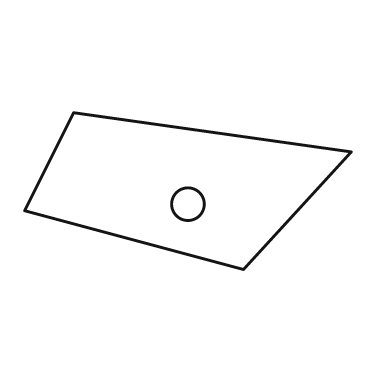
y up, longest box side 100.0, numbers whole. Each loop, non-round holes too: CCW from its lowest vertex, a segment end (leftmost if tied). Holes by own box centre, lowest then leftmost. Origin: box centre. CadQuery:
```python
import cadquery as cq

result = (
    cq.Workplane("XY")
    .moveTo(17.0, -24.0)
    .lineTo(50.0, 12.0)
    .lineTo(-35.0, 24.0)
    .lineTo(-50.0, -6.0)
    .close()
    .moveTo(0.0, -4.0)
    .circle(5.0)
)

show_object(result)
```